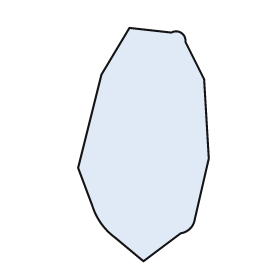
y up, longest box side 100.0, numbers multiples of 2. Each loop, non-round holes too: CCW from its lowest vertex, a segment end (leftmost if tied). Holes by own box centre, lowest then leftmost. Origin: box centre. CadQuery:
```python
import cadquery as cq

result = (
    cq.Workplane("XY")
    .moveTo(0.0, -50.0)
    .lineTo(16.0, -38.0)
    .threePointArc((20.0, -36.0), (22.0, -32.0))
    .lineTo(28.0, -6.0)
    .lineTo(26.0, 28.0)
    .lineTo(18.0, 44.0)
    .threePointArc((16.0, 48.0), (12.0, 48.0))
    .lineTo(-6.0, 50.0)
    .lineTo(-18.0, 30.0)
    .lineTo(-28.0, -10.0)
    .lineTo(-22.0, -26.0)
    .threePointArc((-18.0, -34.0), (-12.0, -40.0))
    .close()
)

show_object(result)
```